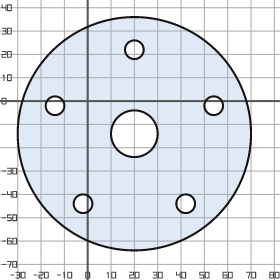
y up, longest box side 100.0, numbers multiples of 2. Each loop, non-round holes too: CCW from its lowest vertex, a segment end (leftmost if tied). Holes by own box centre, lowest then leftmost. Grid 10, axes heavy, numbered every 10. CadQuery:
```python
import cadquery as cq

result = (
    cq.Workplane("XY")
    .moveTo(20.0, -14.0)
    .circle(50.0)
    .moveTo(-2.0, -44.0)
    .circle(4.0)
    .moveTo(42.0, -44.0)
    .circle(4.0)
    .moveTo(20.0, -14.0)
    .circle(10.0)
    .moveTo(-14.0, -2.0)
    .circle(4.0)
    .moveTo(54.0, -2.0)
    .circle(4.0)
    .moveTo(20.0, 22.0)
    .circle(4.0)
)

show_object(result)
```